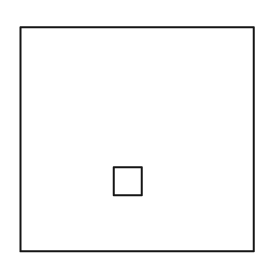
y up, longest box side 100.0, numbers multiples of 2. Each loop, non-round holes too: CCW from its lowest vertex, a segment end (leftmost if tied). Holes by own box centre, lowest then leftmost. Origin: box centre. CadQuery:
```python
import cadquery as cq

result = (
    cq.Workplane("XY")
    .moveTo(-50.0, -48.0)
    .lineTo(50.0, -48.0)
    .lineTo(50.0, 48.0)
    .lineTo(-50.0, 48.0)
    .close()
    .moveTo(-10.0, -24.0)
    .lineTo(2.0, -24.0)
    .lineTo(2.0, -12.0)
    .lineTo(-10.0, -12.0)
    .close()
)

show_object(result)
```